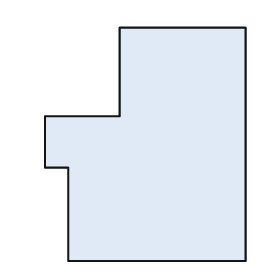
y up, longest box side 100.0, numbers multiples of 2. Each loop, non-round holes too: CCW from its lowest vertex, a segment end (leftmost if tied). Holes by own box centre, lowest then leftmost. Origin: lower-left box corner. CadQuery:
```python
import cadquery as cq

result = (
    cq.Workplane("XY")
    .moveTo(10.0, 0.0)
    .lineTo(86.0, 0.0)
    .lineTo(86.0, 100.0)
    .lineTo(32.0, 100.0)
    .lineTo(32.0, 62.0)
    .lineTo(0.0, 62.0)
    .lineTo(0.0, 40.0)
    .lineTo(10.0, 40.0)
    .close()
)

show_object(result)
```